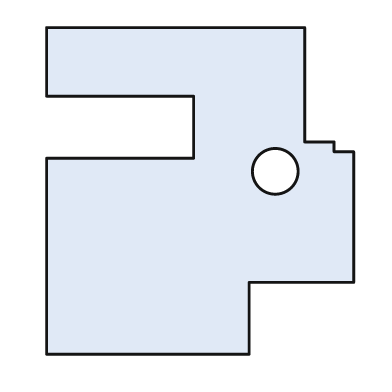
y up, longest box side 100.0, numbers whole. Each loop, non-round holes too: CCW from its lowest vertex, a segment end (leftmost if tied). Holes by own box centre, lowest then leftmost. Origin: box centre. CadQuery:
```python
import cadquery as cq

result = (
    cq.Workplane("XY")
    .moveTo(-47.0, -50.0)
    .lineTo(15.0, -50.0)
    .lineTo(15.0, -28.0)
    .lineTo(47.0, -28.0)
    .lineTo(47.0, 12.0)
    .lineTo(41.0, 12.0)
    .lineTo(41.0, 15.0)
    .lineTo(32.0, 15.0)
    .lineTo(32.0, 50.0)
    .lineTo(-47.0, 50.0)
    .lineTo(-47.0, 29.0)
    .lineTo(-2.0, 29.0)
    .lineTo(-2.0, 10.0)
    .lineTo(-47.0, 10.0)
    .close()
    .moveTo(23.0, 6.0)
    .circle(7.0)
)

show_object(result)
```